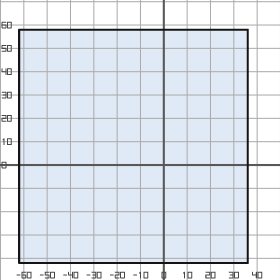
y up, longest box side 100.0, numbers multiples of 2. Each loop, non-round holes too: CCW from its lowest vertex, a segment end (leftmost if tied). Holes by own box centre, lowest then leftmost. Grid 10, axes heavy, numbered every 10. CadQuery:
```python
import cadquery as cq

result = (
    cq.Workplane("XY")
    .moveTo(-62.0, -42.0)
    .lineTo(36.0, -42.0)
    .lineTo(36.0, 58.0)
    .lineTo(-62.0, 58.0)
    .close()
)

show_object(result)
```